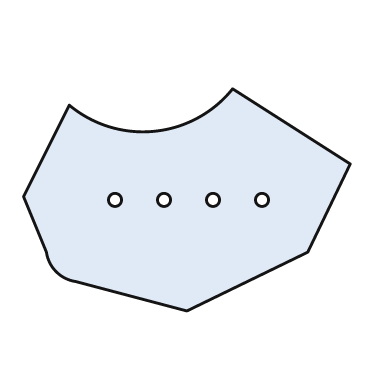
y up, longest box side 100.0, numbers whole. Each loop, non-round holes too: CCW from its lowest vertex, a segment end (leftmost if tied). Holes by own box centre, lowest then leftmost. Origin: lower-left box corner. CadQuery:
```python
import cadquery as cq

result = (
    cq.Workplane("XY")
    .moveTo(50.0, 0.0)
    .lineTo(87.0, 18.0)
    .lineTo(100.0, 45.0)
    .lineTo(64.0, 68.0)
    .threePointArc((40.0, 55.0), (14.0, 63.0))
    .lineTo(0.0, 35.0)
    .lineTo(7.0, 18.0)
    .threePointArc((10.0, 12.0), (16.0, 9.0))
    .close()
    .moveTo(28.0, 34.0)
    .circle(2.0)
    .moveTo(43.0, 34.0)
    .circle(2.0)
    .moveTo(58.0, 34.0)
    .circle(2.0)
    .moveTo(73.0, 34.0)
    .circle(2.0)
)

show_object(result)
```